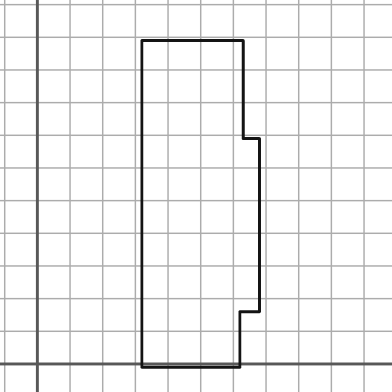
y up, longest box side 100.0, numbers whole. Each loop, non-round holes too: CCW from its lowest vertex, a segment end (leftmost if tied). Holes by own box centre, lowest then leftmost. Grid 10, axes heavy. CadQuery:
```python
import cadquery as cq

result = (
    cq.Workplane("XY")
    .moveTo(32.0, -1.0)
    .lineTo(62.0, -1.0)
    .lineTo(62.0, 16.0)
    .lineTo(68.0, 16.0)
    .lineTo(68.0, 69.0)
    .lineTo(63.0, 69.0)
    .lineTo(63.0, 99.0)
    .lineTo(32.0, 99.0)
    .close()
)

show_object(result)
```